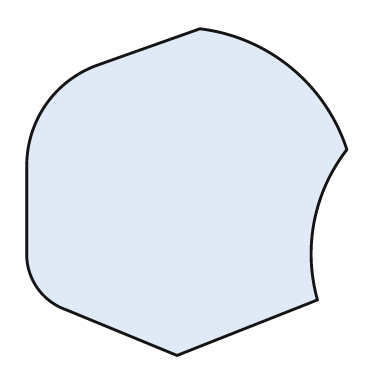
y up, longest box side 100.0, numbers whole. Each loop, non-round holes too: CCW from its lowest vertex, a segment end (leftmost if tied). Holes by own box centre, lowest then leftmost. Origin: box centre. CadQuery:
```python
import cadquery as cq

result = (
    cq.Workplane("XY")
    .moveTo(-3.0, -50.0)
    .lineTo(40.0, -33.0)
    .threePointArc((39.0, -9.0), (49.0, 13.0))
    .threePointArc((32.0, 38.0), (4.0, 50.0))
    .lineTo(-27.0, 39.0)
    .threePointArc((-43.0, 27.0), (-49.0, 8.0))
    .lineTo(-49.0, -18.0)
    .threePointArc((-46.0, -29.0), (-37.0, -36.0))
    .close()
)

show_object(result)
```